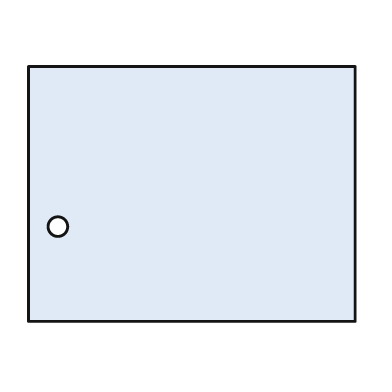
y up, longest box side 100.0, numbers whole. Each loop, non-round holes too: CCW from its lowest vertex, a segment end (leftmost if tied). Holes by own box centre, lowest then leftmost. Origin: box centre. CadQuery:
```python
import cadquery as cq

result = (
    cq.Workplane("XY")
    .moveTo(-50.0, -39.0)
    .lineTo(50.0, -39.0)
    .lineTo(50.0, 39.0)
    .lineTo(-50.0, 39.0)
    .close()
    .moveTo(-41.0, -10.0)
    .circle(3.0)
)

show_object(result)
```